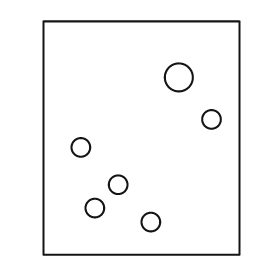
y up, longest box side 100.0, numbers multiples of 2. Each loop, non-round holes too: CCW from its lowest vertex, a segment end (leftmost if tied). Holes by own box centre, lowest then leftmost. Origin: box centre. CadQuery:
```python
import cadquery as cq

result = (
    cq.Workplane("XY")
    .moveTo(-42.0, -50.0)
    .lineTo(42.0, -50.0)
    .lineTo(42.0, 50.0)
    .lineTo(-42.0, 50.0)
    .close()
    .moveTo(4.0, -36.0)
    .circle(4.0)
    .moveTo(-20.0, -30.0)
    .circle(4.0)
    .moveTo(-10.0, -20.0)
    .circle(4.0)
    .moveTo(-26.0, -4.0)
    .circle(4.0)
    .moveTo(30.0, 8.0)
    .circle(4.0)
    .moveTo(16.0, 26.0)
    .circle(6.0)
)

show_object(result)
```